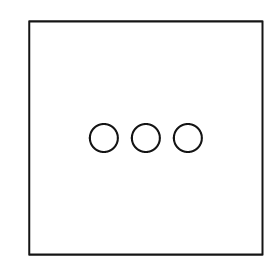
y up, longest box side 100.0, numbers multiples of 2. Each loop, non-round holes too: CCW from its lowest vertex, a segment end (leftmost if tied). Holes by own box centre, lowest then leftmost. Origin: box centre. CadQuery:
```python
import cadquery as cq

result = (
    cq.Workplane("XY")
    .moveTo(-50.0, -50.0)
    .lineTo(50.0, -50.0)
    .lineTo(50.0, 50.0)
    .lineTo(-50.0, 50.0)
    .close()
    .moveTo(-18.0, 0.0)
    .circle(6.0)
    .moveTo(0.0, 0.0)
    .circle(6.0)
    .moveTo(18.0, 0.0)
    .circle(6.0)
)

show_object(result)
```